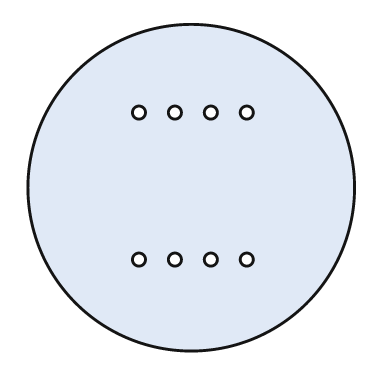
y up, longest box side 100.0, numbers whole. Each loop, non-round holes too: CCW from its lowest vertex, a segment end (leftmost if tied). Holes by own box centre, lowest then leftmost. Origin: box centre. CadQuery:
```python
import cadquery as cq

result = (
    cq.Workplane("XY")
    .moveTo(0.0, 0.0)
    .circle(50.0)
    .moveTo(-16.0, -22.0)
    .circle(2.0)
    .moveTo(-5.0, -22.0)
    .circle(2.0)
    .moveTo(6.0, -22.0)
    .circle(2.0)
    .moveTo(17.0, -22.0)
    .circle(2.0)
    .moveTo(-16.0, 23.0)
    .circle(2.0)
    .moveTo(-5.0, 23.0)
    .circle(2.0)
    .moveTo(6.0, 23.0)
    .circle(2.0)
    .moveTo(17.0, 23.0)
    .circle(2.0)
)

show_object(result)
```